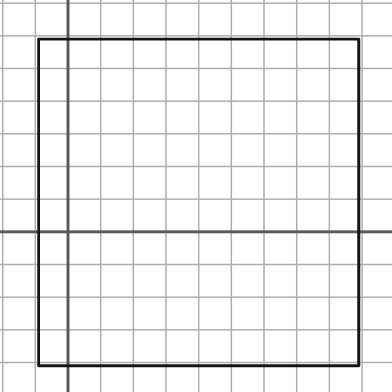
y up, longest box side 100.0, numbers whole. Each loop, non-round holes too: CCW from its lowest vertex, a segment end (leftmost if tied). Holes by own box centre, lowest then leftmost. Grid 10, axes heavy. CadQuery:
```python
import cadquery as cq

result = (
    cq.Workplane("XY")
    .moveTo(-9.0, -41.0)
    .lineTo(89.0, -41.0)
    .lineTo(89.0, 59.0)
    .lineTo(-9.0, 59.0)
    .close()
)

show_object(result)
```